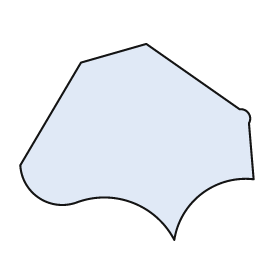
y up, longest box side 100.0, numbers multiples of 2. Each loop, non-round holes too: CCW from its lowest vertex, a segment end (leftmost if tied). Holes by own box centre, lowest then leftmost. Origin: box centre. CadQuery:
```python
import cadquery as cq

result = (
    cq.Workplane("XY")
    .moveTo(16.0, -42.0)
    .threePointArc((28.0, -22.0), (50.0, -16.0))
    .lineTo(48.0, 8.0)
    .threePointArc((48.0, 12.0), (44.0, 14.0))
    .lineTo(4.0, 42.0)
    .lineTo(-24.0, 34.0)
    .lineTo(-50.0, -10.0)
    .threePointArc((-42.0, -24.0), (-26.0, -26.0))
    .threePointArc((-2.0, -26.0), (16.0, -42.0))
    .close()
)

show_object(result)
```